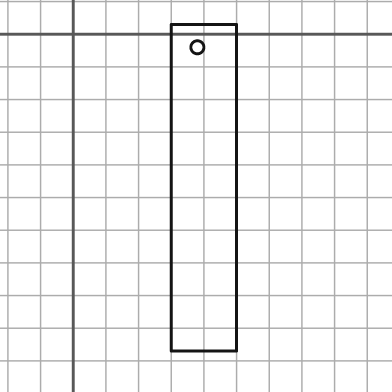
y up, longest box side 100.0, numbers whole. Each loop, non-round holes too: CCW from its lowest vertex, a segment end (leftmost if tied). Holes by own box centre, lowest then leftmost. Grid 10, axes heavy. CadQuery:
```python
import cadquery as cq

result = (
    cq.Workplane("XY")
    .moveTo(30.0, -97.0)
    .lineTo(50.0, -97.0)
    .lineTo(50.0, 3.0)
    .lineTo(30.0, 3.0)
    .close()
    .moveTo(38.0, -4.0)
    .circle(2.0)
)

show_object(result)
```